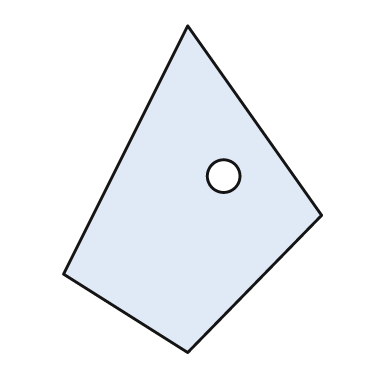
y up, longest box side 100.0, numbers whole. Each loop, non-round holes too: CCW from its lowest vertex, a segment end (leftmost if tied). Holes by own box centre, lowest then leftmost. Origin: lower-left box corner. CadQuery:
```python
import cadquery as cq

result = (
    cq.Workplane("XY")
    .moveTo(38.0, 0.0)
    .lineTo(79.0, 42.0)
    .lineTo(38.0, 100.0)
    .lineTo(0.0, 24.0)
    .close()
    .moveTo(49.0, 54.0)
    .circle(5.0)
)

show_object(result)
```